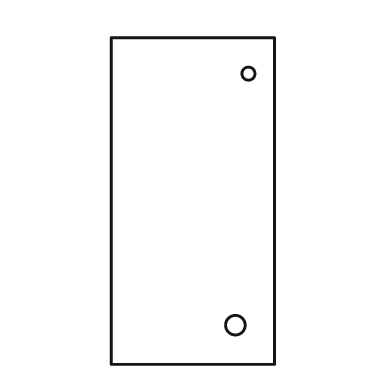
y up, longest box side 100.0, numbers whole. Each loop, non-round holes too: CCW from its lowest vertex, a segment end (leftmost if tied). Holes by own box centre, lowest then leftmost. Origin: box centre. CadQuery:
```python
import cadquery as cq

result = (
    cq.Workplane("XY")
    .moveTo(-25.0, -50.0)
    .lineTo(25.0, -50.0)
    .lineTo(25.0, 50.0)
    .lineTo(-25.0, 50.0)
    .close()
    .moveTo(13.0, -38.0)
    .circle(3.0)
    .moveTo(17.0, 39.0)
    .circle(2.0)
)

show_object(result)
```